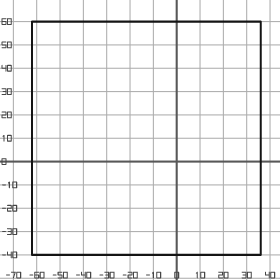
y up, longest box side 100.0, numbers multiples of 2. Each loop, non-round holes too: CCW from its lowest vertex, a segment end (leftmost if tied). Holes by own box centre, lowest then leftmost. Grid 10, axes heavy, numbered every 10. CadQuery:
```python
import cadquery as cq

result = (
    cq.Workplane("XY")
    .moveTo(-62.0, -40.0)
    .lineTo(36.0, -40.0)
    .lineTo(36.0, 60.0)
    .lineTo(-62.0, 60.0)
    .close()
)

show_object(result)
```